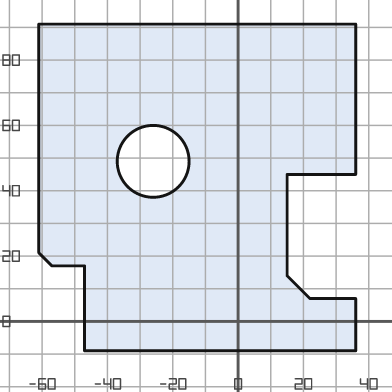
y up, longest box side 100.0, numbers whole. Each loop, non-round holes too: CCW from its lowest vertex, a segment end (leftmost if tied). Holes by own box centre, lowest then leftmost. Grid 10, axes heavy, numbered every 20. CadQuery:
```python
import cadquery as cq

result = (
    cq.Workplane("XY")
    .moveTo(-47.0, -9.0)
    .lineTo(36.0, -9.0)
    .lineTo(36.0, 7.0)
    .lineTo(22.0, 7.0)
    .lineTo(15.0, 14.0)
    .lineTo(15.0, 45.0)
    .lineTo(36.0, 45.0)
    .lineTo(36.0, 91.0)
    .lineTo(-61.0, 91.0)
    .lineTo(-61.0, 21.0)
    .lineTo(-57.0, 17.0)
    .lineTo(-47.0, 17.0)
    .close()
    .moveTo(-26.0, 49.0)
    .circle(11.0)
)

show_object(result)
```